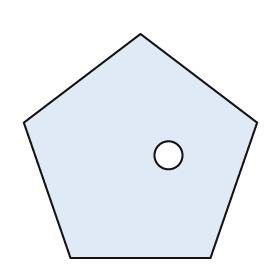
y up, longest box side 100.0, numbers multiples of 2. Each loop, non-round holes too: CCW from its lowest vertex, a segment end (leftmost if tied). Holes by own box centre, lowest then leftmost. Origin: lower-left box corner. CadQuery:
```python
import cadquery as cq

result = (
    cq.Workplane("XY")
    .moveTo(20.0, 0.0)
    .lineTo(80.0, 0.0)
    .lineTo(100.0, 58.0)
    .lineTo(50.0, 96.0)
    .lineTo(0.0, 58.0)
    .close()
    .moveTo(62.0, 44.0)
    .circle(6.0)
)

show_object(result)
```